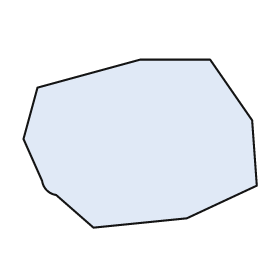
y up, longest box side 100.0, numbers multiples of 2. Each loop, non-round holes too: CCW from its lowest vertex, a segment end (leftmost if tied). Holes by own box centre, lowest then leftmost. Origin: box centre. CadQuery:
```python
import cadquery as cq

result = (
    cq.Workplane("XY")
    .moveTo(-20.0, -36.0)
    .lineTo(20.0, -32.0)
    .lineTo(50.0, -18.0)
    .lineTo(48.0, 10.0)
    .lineTo(30.0, 36.0)
    .lineTo(0.0, 36.0)
    .lineTo(-44.0, 24.0)
    .lineTo(-50.0, 2.0)
    .lineTo(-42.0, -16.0)
    .threePointArc((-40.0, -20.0), (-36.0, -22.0))
    .close()
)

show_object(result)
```